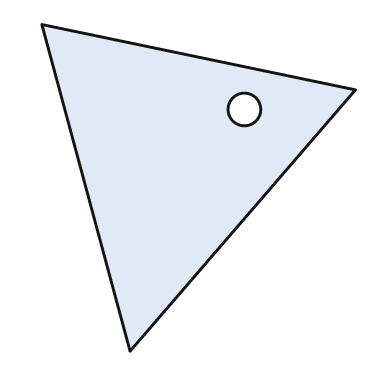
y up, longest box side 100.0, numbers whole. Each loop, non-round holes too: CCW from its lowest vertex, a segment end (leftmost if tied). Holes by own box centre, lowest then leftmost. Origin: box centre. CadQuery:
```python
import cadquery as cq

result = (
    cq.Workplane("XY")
    .moveTo(-21.0, -50.0)
    .lineTo(48.0, 30.0)
    .lineTo(-48.0, 50.0)
    .close()
    .moveTo(14.0, 24.0)
    .circle(5.0)
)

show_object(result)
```